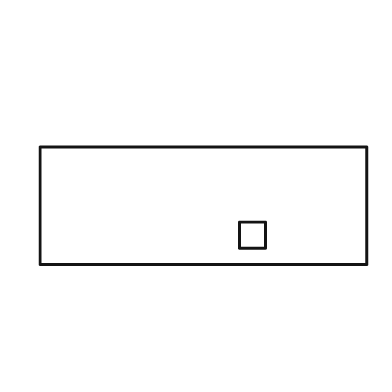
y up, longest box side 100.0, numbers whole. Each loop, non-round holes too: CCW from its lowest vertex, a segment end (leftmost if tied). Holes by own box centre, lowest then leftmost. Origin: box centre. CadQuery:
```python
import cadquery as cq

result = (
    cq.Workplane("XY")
    .moveTo(-50.0, -18.0)
    .lineTo(50.0, -18.0)
    .lineTo(50.0, 18.0)
    .lineTo(-50.0, 18.0)
    .close()
    .moveTo(11.0, -13.0)
    .lineTo(19.0, -13.0)
    .lineTo(19.0, -5.0)
    .lineTo(11.0, -5.0)
    .close()
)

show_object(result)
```